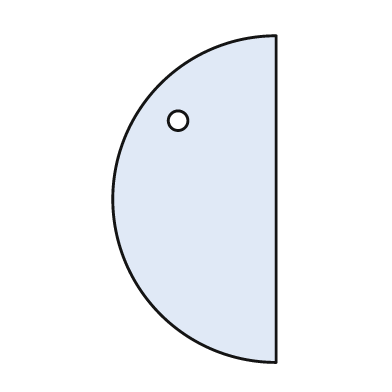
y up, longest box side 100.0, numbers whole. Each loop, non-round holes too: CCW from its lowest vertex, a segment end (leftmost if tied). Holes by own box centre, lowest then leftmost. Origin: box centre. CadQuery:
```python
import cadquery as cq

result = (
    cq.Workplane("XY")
    .moveTo(25.0, -50.0)
    .lineTo(25.0, 50.0)
    .threePointArc((-25.0, 0.0), (25.0, -50.0))
    .close()
    .moveTo(-5.0, 24.0)
    .circle(3.0)
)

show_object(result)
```